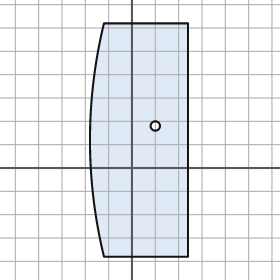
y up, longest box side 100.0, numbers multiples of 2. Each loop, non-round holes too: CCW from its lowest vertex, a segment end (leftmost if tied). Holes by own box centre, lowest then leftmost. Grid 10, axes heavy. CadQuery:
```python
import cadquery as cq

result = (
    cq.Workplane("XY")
    .moveTo(-12.0, -38.0)
    .lineTo(24.0, -38.0)
    .lineTo(24.0, 62.0)
    .lineTo(-12.0, 62.0)
    .threePointArc((-18.0, 12.0), (-12.0, -38.0))
    .close()
    .moveTo(10.0, 18.0)
    .circle(2.0)
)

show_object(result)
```